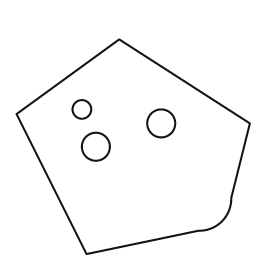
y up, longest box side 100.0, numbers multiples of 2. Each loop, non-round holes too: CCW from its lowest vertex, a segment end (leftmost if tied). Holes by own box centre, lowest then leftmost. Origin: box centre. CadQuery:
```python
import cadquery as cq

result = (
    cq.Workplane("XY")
    .moveTo(-20.0, -46.0)
    .lineTo(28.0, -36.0)
    .threePointArc((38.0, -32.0), (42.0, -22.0))
    .lineTo(50.0, 10.0)
    .lineTo(-6.0, 46.0)
    .lineTo(-50.0, 14.0)
    .close()
    .moveTo(-16.0, 0.0)
    .circle(6.0)
    .moveTo(12.0, 10.0)
    .circle(6.0)
    .moveTo(-22.0, 16.0)
    .circle(4.0)
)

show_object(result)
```